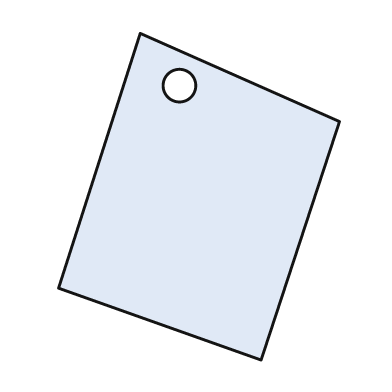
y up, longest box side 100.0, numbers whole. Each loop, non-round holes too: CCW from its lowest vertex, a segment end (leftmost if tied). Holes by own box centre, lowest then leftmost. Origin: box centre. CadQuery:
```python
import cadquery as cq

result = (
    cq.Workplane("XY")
    .moveTo(19.0, -50.0)
    .lineTo(43.0, 23.0)
    .lineTo(-18.0, 50.0)
    .lineTo(-43.0, -28.0)
    .close()
    .moveTo(-6.0, 34.0)
    .circle(5.0)
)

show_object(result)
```